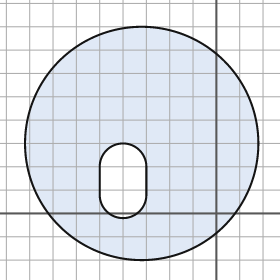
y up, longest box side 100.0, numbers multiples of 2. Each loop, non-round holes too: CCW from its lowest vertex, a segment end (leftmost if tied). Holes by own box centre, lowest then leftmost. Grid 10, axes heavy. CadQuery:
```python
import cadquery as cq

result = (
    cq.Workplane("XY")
    .moveTo(-32.0, 30.0)
    .circle(50.0)
    .moveTo(-50.0, 8.0)
    .threePointArc((-40.0, -2.0), (-30.0, 8.0))
    .lineTo(-30.0, 20.0)
    .threePointArc((-40.0, 30.0), (-50.0, 20.0))
    .close()
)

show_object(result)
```